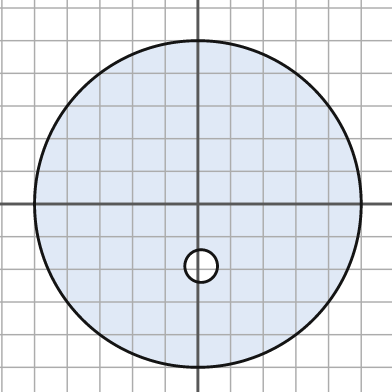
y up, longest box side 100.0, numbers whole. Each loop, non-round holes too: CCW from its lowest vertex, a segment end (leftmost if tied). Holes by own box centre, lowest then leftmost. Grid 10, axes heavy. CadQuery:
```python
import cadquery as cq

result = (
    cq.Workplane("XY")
    .moveTo(0.0, 0.0)
    .circle(50.0)
    .moveTo(1.0, -19.0)
    .circle(5.0)
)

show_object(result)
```